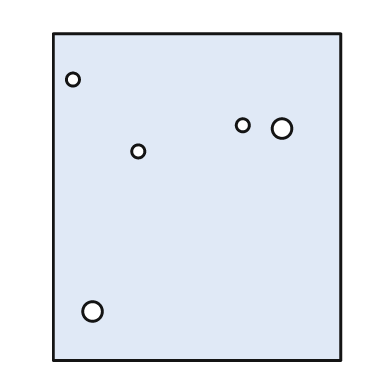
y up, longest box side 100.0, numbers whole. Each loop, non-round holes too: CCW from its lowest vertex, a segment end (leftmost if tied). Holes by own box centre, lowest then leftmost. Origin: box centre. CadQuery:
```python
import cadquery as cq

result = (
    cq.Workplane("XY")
    .moveTo(-44.0, -50.0)
    .lineTo(44.0, -50.0)
    .lineTo(44.0, 50.0)
    .lineTo(-44.0, 50.0)
    .close()
    .moveTo(-32.0, -35.0)
    .circle(3.0)
    .moveTo(-18.0, 14.0)
    .circle(2.0)
    .moveTo(26.0, 21.0)
    .circle(3.0)
    .moveTo(14.0, 22.0)
    .circle(2.0)
    .moveTo(-38.0, 36.0)
    .circle(2.0)
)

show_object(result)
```